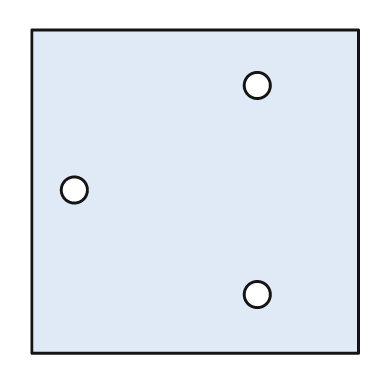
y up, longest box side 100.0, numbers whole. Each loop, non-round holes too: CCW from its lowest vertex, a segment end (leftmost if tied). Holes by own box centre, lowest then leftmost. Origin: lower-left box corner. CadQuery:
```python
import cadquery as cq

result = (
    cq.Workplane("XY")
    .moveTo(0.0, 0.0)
    .lineTo(100.0, 0.0)
    .lineTo(100.0, 99.0)
    .lineTo(0.0, 99.0)
    .close()
    .moveTo(69.0, 18.0)
    .circle(4.0)
    .moveTo(13.0, 50.0)
    .circle(4.0)
    .moveTo(69.0, 82.0)
    .circle(4.0)
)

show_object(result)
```